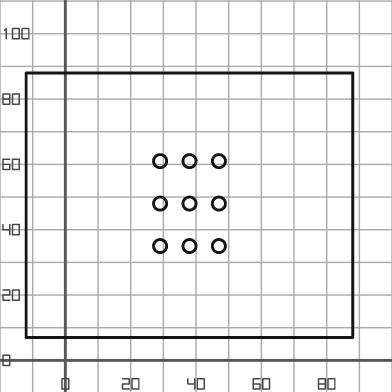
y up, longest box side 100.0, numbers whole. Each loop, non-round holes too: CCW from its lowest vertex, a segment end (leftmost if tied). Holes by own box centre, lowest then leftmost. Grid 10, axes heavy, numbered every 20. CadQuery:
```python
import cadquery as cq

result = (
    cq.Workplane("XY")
    .moveTo(-12.0, 7.0)
    .lineTo(88.0, 7.0)
    .lineTo(88.0, 88.0)
    .lineTo(-12.0, 88.0)
    .close()
    .moveTo(29.0, 35.0)
    .circle(2.0)
    .moveTo(38.0, 35.0)
    .circle(2.0)
    .moveTo(47.0, 35.0)
    .circle(2.0)
    .moveTo(29.0, 48.0)
    .circle(2.0)
    .moveTo(38.0, 48.0)
    .circle(2.0)
    .moveTo(47.0, 48.0)
    .circle(2.0)
    .moveTo(29.0, 61.0)
    .circle(2.0)
    .moveTo(38.0, 61.0)
    .circle(2.0)
    .moveTo(47.0, 61.0)
    .circle(2.0)
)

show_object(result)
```